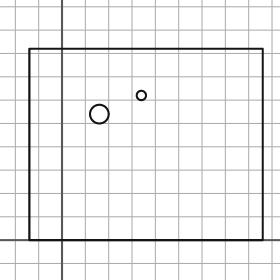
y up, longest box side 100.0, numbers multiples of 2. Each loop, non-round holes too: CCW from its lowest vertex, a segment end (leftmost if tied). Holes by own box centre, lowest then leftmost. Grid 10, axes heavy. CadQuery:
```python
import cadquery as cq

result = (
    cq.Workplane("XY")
    .moveTo(-14.0, 0.0)
    .lineTo(86.0, 0.0)
    .lineTo(86.0, 82.0)
    .lineTo(-14.0, 82.0)
    .close()
    .moveTo(16.0, 54.0)
    .circle(4.0)
    .moveTo(34.0, 62.0)
    .circle(2.0)
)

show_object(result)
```